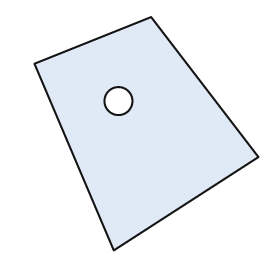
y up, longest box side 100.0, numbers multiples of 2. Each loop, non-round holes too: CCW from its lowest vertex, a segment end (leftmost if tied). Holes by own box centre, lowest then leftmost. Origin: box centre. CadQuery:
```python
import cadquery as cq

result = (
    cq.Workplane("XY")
    .moveTo(-14.0, -50.0)
    .lineTo(48.0, -10.0)
    .lineTo(2.0, 50.0)
    .lineTo(-48.0, 30.0)
    .close()
    .moveTo(-12.0, 14.0)
    .circle(6.0)
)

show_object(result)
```